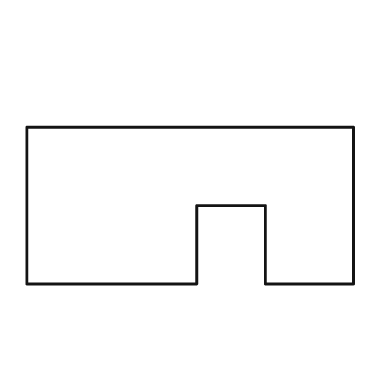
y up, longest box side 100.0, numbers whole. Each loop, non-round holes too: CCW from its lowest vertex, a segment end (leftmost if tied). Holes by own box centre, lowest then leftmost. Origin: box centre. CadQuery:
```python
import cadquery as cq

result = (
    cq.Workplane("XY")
    .moveTo(-50.0, -24.0)
    .lineTo(2.0, -24.0)
    .lineTo(2.0, 0.0)
    .lineTo(23.0, 0.0)
    .lineTo(23.0, -24.0)
    .lineTo(50.0, -24.0)
    .lineTo(50.0, 24.0)
    .lineTo(-50.0, 24.0)
    .close()
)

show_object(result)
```